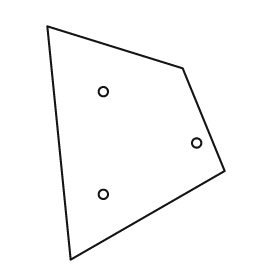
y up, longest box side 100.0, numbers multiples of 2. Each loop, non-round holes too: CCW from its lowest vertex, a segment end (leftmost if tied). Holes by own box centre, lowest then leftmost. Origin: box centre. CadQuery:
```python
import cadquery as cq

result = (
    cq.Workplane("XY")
    .moveTo(-28.0, -50.0)
    .lineTo(38.0, -12.0)
    .lineTo(20.0, 32.0)
    .lineTo(-38.0, 50.0)
    .close()
    .moveTo(-14.0, -22.0)
    .circle(2.0)
    .moveTo(26.0, 0.0)
    .circle(2.0)
    .moveTo(-14.0, 22.0)
    .circle(2.0)
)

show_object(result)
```